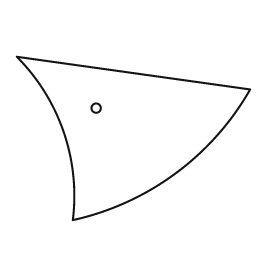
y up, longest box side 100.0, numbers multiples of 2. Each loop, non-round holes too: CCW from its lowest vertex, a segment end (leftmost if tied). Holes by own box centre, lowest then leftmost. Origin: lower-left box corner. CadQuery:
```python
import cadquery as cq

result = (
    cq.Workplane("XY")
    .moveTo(24.0, 0.0)
    .threePointArc((68.0, 20.0), (100.0, 56.0))
    .lineTo(0.0, 70.0)
    .threePointArc((20.0, 38.0), (24.0, 0.0))
    .close()
    .moveTo(34.0, 48.0)
    .circle(2.0)
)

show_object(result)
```